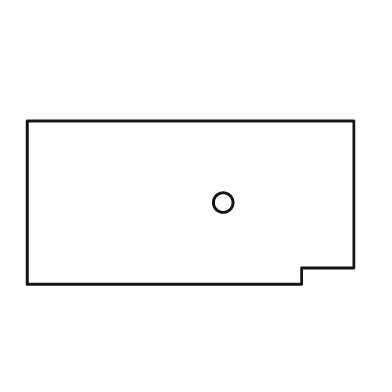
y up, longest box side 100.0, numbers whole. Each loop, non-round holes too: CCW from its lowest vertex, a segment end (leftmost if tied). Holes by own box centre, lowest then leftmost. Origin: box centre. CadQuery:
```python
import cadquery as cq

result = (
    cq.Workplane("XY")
    .moveTo(-50.0, -25.0)
    .lineTo(34.0, -25.0)
    .lineTo(34.0, -20.0)
    .lineTo(50.0, -20.0)
    .lineTo(50.0, 25.0)
    .lineTo(-50.0, 25.0)
    .close()
    .moveTo(10.0, 0.0)
    .circle(3.0)
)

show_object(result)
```